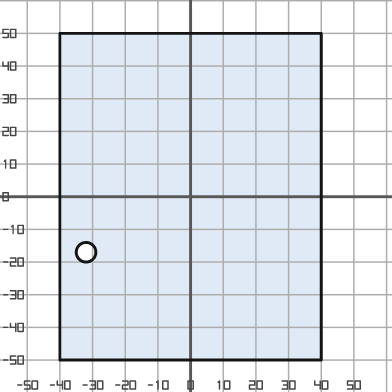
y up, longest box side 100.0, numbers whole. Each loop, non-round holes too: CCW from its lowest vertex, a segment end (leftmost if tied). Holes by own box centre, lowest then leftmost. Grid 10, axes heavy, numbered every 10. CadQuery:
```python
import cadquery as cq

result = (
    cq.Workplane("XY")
    .moveTo(-40.0, -50.0)
    .lineTo(40.0, -50.0)
    .lineTo(40.0, 50.0)
    .lineTo(-40.0, 50.0)
    .close()
    .moveTo(-32.0, -17.0)
    .circle(3.0)
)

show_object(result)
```